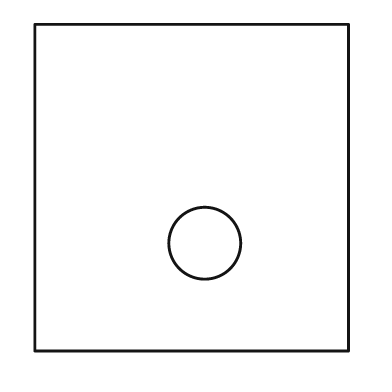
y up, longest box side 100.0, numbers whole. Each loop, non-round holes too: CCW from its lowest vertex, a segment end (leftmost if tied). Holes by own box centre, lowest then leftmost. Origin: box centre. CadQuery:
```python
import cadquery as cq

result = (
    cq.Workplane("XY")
    .moveTo(-48.0, -50.0)
    .lineTo(48.0, -50.0)
    .lineTo(48.0, 50.0)
    .lineTo(-48.0, 50.0)
    .close()
    .moveTo(4.0, -17.0)
    .circle(11.0)
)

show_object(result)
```